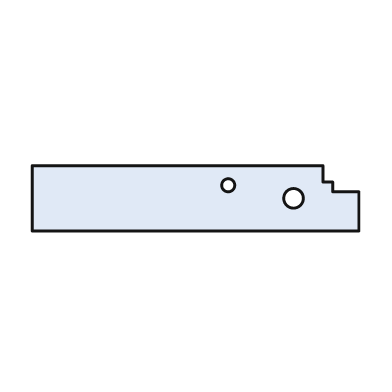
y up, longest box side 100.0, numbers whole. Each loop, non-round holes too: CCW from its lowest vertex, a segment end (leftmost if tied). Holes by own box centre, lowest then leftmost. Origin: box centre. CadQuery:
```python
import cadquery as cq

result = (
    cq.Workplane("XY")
    .moveTo(-50.0, -10.0)
    .lineTo(50.0, -10.0)
    .lineTo(50.0, 2.0)
    .lineTo(42.0, 2.0)
    .lineTo(42.0, 5.0)
    .lineTo(39.0, 5.0)
    .lineTo(39.0, 10.0)
    .lineTo(-50.0, 10.0)
    .close()
    .moveTo(30.0, 0.0)
    .circle(3.0)
    .moveTo(10.0, 4.0)
    .circle(2.0)
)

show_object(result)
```